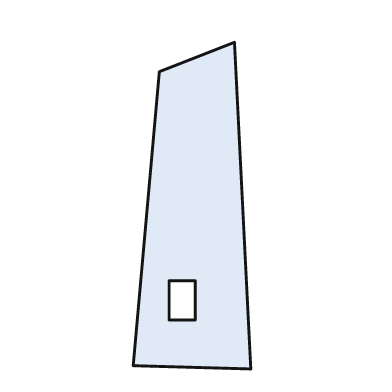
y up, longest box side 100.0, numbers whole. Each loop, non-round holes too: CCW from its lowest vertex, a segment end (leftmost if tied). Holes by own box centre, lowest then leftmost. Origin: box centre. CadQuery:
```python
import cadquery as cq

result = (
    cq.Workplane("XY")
    .moveTo(18.0, -50.0)
    .lineTo(13.0, 50.0)
    .lineTo(-10.0, 41.0)
    .lineTo(-18.0, -49.0)
    .close()
    .moveTo(-7.0, -35.0)
    .lineTo(1.0, -35.0)
    .lineTo(1.0, -23.0)
    .lineTo(-7.0, -23.0)
    .close()
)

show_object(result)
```